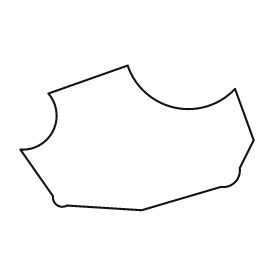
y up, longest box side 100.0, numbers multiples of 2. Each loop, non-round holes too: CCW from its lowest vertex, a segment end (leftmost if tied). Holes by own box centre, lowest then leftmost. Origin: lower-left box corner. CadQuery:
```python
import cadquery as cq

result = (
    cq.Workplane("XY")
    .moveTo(52.0, 0.0)
    .lineTo(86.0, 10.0)
    .threePointArc((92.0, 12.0), (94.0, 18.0))
    .lineTo(100.0, 30.0)
    .lineTo(92.0, 52.0)
    .threePointArc((66.0, 44.0), (46.0, 62.0))
    .lineTo(12.0, 50.0)
    .threePointArc((14.0, 34.0), (0.0, 26.0))
    .lineTo(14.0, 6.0)
    .threePointArc((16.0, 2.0), (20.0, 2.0))
    .close()
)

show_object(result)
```